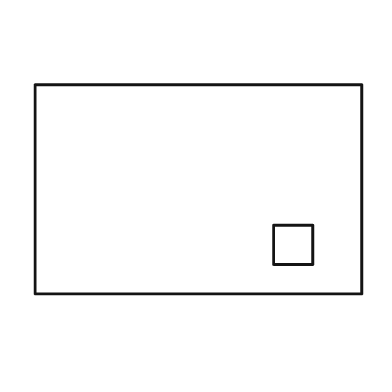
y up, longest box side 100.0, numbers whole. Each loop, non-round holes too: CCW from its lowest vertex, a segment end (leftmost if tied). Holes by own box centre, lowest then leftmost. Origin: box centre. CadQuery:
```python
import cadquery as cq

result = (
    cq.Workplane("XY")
    .moveTo(-50.0, -32.0)
    .lineTo(50.0, -32.0)
    .lineTo(50.0, 32.0)
    .lineTo(-50.0, 32.0)
    .close()
    .moveTo(23.0, -23.0)
    .lineTo(35.0, -23.0)
    .lineTo(35.0, -11.0)
    .lineTo(23.0, -11.0)
    .close()
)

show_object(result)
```